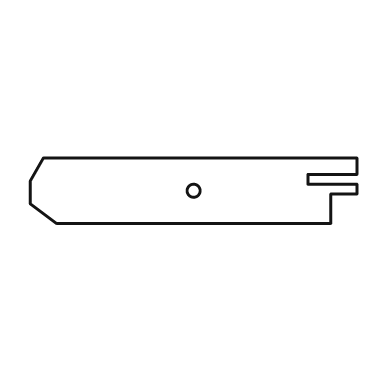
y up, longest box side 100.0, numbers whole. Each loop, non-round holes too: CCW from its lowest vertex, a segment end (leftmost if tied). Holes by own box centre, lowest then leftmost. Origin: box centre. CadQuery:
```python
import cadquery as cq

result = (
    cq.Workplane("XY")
    .moveTo(-42.0, -10.0)
    .lineTo(42.0, -10.0)
    .lineTo(42.0, -1.0)
    .lineTo(50.0, -1.0)
    .lineTo(50.0, 2.0)
    .lineTo(35.0, 2.0)
    .lineTo(35.0, 5.0)
    .lineTo(50.0, 5.0)
    .lineTo(50.0, 10.0)
    .lineTo(-46.0, 10.0)
    .lineTo(-50.0, 3.0)
    .lineTo(-50.0, -4.0)
    .close()
    .moveTo(0.0, 0.0)
    .circle(2.0)
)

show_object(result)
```